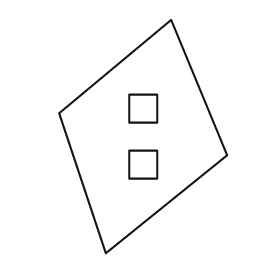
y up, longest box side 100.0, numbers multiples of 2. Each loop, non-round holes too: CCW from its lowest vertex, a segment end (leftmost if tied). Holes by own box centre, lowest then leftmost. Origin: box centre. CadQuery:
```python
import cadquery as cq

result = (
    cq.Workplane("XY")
    .moveTo(-16.0, -50.0)
    .lineTo(36.0, -8.0)
    .lineTo(12.0, 50.0)
    .lineTo(-36.0, 10.0)
    .close()
    .moveTo(-6.0, -18.0)
    .lineTo(6.0, -18.0)
    .lineTo(6.0, -6.0)
    .lineTo(-6.0, -6.0)
    .close()
    .moveTo(-6.0, 6.0)
    .lineTo(6.0, 6.0)
    .lineTo(6.0, 18.0)
    .lineTo(-6.0, 18.0)
    .close()
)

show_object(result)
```